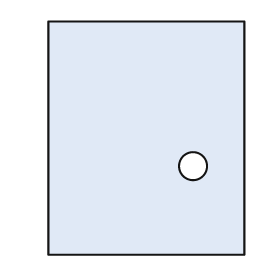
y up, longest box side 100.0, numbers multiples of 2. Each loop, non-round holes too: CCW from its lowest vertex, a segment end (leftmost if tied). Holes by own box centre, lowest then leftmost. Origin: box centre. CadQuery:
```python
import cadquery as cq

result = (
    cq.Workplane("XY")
    .moveTo(-42.0, -50.0)
    .lineTo(42.0, -50.0)
    .lineTo(42.0, 50.0)
    .lineTo(-42.0, 50.0)
    .close()
    .moveTo(20.0, -12.0)
    .circle(6.0)
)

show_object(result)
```